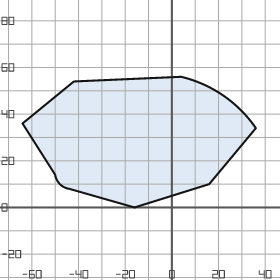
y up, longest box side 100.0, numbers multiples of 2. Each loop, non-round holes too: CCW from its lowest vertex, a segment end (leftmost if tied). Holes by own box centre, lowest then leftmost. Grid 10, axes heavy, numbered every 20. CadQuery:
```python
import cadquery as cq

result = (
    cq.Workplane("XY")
    .moveTo(-16.0, 0.0)
    .lineTo(16.0, 10.0)
    .lineTo(36.0, 34.0)
    .threePointArc((22.0, 48.0), (4.0, 56.0))
    .lineTo(-42.0, 54.0)
    .lineTo(-64.0, 36.0)
    .lineTo(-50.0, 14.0)
    .threePointArc((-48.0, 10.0), (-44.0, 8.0))
    .close()
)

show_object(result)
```